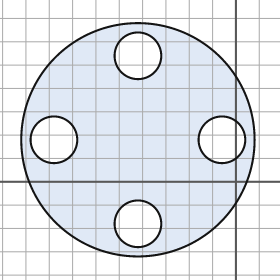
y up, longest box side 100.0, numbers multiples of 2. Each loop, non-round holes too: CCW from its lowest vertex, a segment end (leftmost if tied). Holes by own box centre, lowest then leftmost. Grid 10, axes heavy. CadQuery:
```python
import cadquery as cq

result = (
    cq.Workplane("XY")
    .moveTo(-42.0, 18.0)
    .circle(50.0)
    .moveTo(-42.0, -18.0)
    .circle(10.0)
    .moveTo(-78.0, 18.0)
    .circle(10.0)
    .moveTo(-6.0, 18.0)
    .circle(10.0)
    .moveTo(-42.0, 54.0)
    .circle(10.0)
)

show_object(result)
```